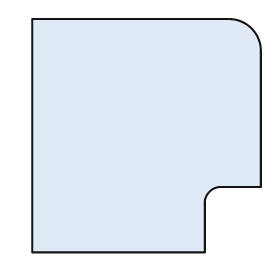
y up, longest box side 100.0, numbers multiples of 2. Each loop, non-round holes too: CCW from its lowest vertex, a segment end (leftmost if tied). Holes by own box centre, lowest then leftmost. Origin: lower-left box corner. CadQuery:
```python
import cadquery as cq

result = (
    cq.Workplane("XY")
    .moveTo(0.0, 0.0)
    .lineTo(74.0, 0.0)
    .lineTo(74.0, 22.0)
    .threePointArc((76.0, 26.0), (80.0, 28.0))
    .lineTo(98.0, 28.0)
    .lineTo(98.0, 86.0)
    .threePointArc((94.0, 96.0), (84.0, 100.0))
    .lineTo(0.0, 100.0)
    .close()
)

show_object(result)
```